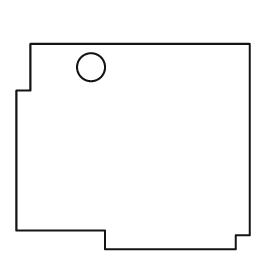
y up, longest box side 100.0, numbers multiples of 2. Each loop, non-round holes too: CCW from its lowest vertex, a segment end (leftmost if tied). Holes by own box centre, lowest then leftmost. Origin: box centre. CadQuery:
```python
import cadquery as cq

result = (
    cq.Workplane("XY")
    .moveTo(-12.0, -44.0)
    .lineTo(44.0, -44.0)
    .lineTo(44.0, -38.0)
    .lineTo(50.0, -38.0)
    .lineTo(50.0, 44.0)
    .lineTo(-44.0, 44.0)
    .lineTo(-44.0, 24.0)
    .lineTo(-50.0, 24.0)
    .lineTo(-50.0, -36.0)
    .lineTo(-12.0, -36.0)
    .close()
    .moveTo(-18.0, 34.0)
    .circle(6.0)
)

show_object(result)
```